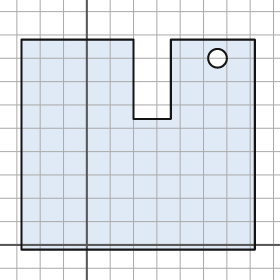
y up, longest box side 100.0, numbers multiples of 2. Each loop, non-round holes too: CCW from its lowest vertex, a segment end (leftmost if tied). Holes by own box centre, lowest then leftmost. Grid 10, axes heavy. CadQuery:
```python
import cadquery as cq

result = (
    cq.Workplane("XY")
    .moveTo(-28.0, -2.0)
    .lineTo(72.0, -2.0)
    .lineTo(72.0, 88.0)
    .lineTo(36.0, 88.0)
    .lineTo(36.0, 54.0)
    .lineTo(20.0, 54.0)
    .lineTo(20.0, 88.0)
    .lineTo(-28.0, 88.0)
    .close()
    .moveTo(56.0, 80.0)
    .circle(4.0)
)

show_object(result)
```